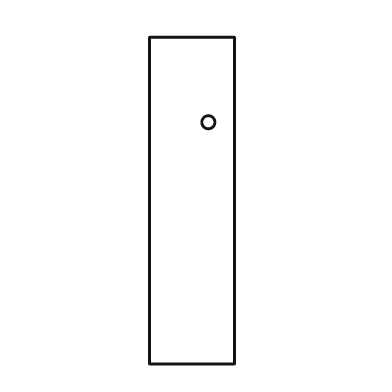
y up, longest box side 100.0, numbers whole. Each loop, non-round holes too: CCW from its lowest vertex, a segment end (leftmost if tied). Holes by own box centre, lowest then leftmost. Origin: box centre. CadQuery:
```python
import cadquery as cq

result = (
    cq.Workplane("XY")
    .moveTo(-13.0, -50.0)
    .lineTo(13.0, -50.0)
    .lineTo(13.0, 50.0)
    .lineTo(-13.0, 50.0)
    .close()
    .moveTo(5.0, 24.0)
    .circle(2.0)
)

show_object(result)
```